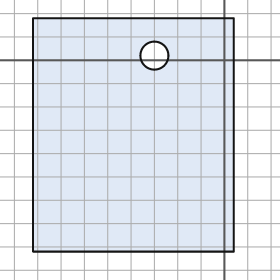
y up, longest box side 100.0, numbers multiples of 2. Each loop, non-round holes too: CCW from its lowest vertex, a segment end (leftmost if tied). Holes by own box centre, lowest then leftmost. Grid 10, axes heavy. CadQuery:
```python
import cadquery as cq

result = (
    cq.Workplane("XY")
    .moveTo(-82.0, -82.0)
    .lineTo(4.0, -82.0)
    .lineTo(4.0, 18.0)
    .lineTo(-82.0, 18.0)
    .close()
    .moveTo(-30.0, 2.0)
    .circle(6.0)
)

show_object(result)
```